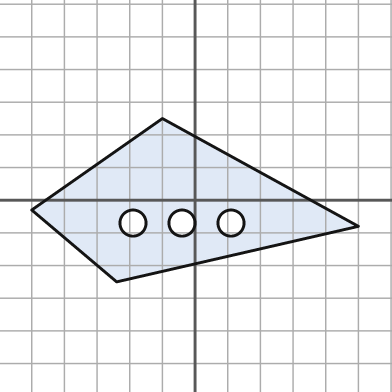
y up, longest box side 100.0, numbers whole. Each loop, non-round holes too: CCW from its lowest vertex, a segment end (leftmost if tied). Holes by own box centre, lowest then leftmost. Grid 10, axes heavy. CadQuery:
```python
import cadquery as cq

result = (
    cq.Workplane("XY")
    .moveTo(-24.0, -25.0)
    .lineTo(50.0, -8.0)
    .lineTo(-10.0, 25.0)
    .lineTo(-50.0, -3.0)
    .close()
    .moveTo(-19.0, -7.0)
    .circle(4.0)
    .moveTo(-4.0, -7.0)
    .circle(4.0)
    .moveTo(11.0, -7.0)
    .circle(4.0)
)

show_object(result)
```